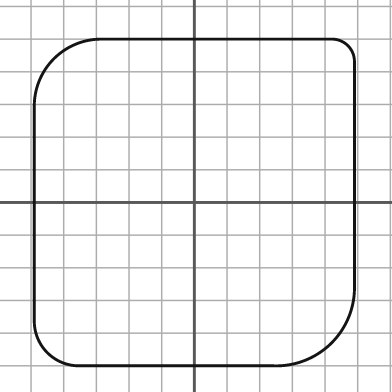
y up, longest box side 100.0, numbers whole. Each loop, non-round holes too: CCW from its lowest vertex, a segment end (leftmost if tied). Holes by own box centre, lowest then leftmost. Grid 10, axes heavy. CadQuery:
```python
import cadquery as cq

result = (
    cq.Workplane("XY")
    .moveTo(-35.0, -50.0)
    .lineTo(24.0, -50.0)
    .threePointArc((42.0, -43.0), (49.0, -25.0))
    .lineTo(49.0, 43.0)
    .threePointArc((47.0, 48.0), (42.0, 50.0))
    .lineTo(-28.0, 50.0)
    .threePointArc((-43.0, 44.0), (-49.0, 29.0))
    .lineTo(-49.0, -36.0)
    .threePointArc((-45.0, -46.0), (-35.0, -50.0))
    .close()
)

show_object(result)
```